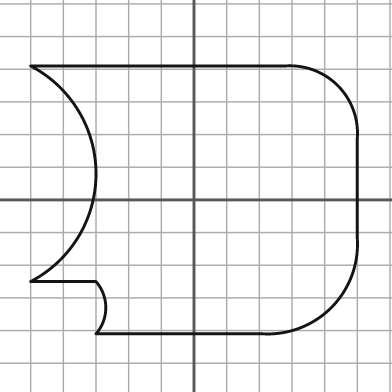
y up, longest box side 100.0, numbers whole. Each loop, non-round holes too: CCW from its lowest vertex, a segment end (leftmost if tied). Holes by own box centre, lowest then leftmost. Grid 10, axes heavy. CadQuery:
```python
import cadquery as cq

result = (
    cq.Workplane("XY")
    .moveTo(-30.0, -41.0)
    .lineTo(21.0, -41.0)
    .threePointArc((42.0, -33.0), (50.0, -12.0))
    .lineTo(50.0, 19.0)
    .threePointArc((44.0, 35.0), (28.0, 41.0))
    .lineTo(-50.0, 41.0)
    .threePointArc((-30.0, 8.0), (-50.0, -25.0))
    .lineTo(-30.0, -25.0)
    .threePointArc((-27.0, -33.0), (-30.0, -41.0))
    .close()
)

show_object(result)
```